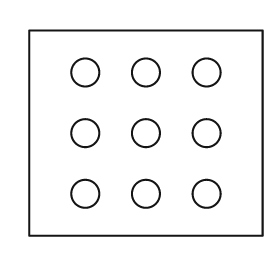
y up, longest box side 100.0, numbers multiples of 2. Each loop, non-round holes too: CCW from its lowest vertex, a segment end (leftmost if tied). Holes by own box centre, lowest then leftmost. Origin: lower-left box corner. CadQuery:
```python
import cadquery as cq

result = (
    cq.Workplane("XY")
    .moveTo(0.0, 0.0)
    .lineTo(100.0, 0.0)
    .lineTo(100.0, 88.0)
    .lineTo(0.0, 88.0)
    .close()
    .moveTo(24.0, 18.0)
    .circle(6.0)
    .moveTo(50.0, 18.0)
    .circle(6.0)
    .moveTo(76.0, 18.0)
    .circle(6.0)
    .moveTo(24.0, 44.0)
    .circle(6.0)
    .moveTo(50.0, 44.0)
    .circle(6.0)
    .moveTo(76.0, 44.0)
    .circle(6.0)
    .moveTo(24.0, 70.0)
    .circle(6.0)
    .moveTo(50.0, 70.0)
    .circle(6.0)
    .moveTo(76.0, 70.0)
    .circle(6.0)
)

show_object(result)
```